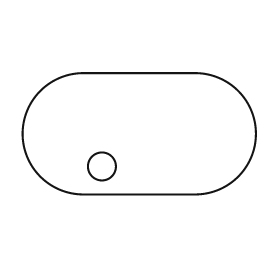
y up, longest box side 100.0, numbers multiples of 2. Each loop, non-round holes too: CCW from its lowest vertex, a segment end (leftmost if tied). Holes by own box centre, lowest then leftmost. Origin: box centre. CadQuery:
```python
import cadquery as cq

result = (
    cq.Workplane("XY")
    .moveTo(-24.0, -26.0)
    .lineTo(24.0, -26.0)
    .threePointArc((50.0, 0.0), (24.0, 26.0))
    .lineTo(-24.0, 26.0)
    .threePointArc((-50.0, 0.0), (-24.0, -26.0))
    .close()
    .moveTo(-16.0, -14.0)
    .circle(6.0)
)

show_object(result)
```